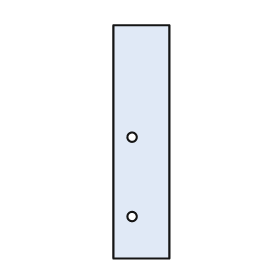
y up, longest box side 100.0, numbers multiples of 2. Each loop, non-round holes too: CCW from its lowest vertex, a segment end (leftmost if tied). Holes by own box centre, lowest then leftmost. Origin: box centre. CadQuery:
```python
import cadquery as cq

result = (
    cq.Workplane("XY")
    .moveTo(-12.0, -50.0)
    .lineTo(12.0, -50.0)
    .lineTo(12.0, 50.0)
    .lineTo(-12.0, 50.0)
    .close()
    .moveTo(-4.0, -32.0)
    .circle(2.0)
    .moveTo(-4.0, 2.0)
    .circle(2.0)
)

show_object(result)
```